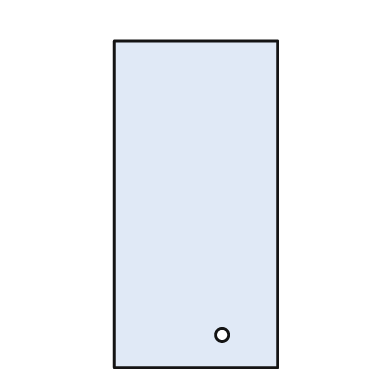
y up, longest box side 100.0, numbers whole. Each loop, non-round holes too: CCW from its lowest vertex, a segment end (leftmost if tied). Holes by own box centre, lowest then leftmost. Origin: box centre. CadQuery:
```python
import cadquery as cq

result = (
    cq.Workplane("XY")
    .moveTo(-25.0, -50.0)
    .lineTo(25.0, -50.0)
    .lineTo(25.0, 50.0)
    .lineTo(-25.0, 50.0)
    .close()
    .moveTo(8.0, -40.0)
    .circle(2.0)
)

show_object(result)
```